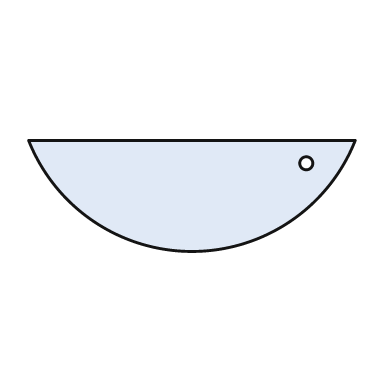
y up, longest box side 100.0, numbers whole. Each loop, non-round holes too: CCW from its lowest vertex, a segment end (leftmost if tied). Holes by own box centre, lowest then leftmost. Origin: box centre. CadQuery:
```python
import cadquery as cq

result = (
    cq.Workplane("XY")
    .moveTo(-50.0, 17.0)
    .threePointArc((0.0, -17.0), (50.0, 17.0))
    .close()
    .moveTo(35.0, 10.0)
    .circle(2.0)
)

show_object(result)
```